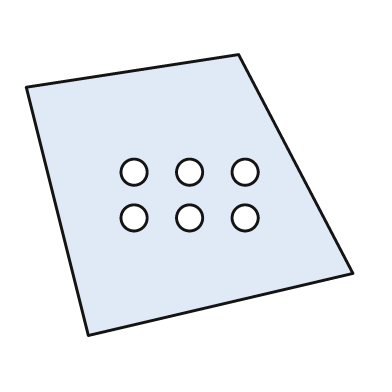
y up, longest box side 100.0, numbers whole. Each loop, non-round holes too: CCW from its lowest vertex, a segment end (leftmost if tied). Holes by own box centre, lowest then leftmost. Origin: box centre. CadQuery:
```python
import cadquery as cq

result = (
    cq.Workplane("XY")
    .moveTo(-31.0, -43.0)
    .lineTo(50.0, -24.0)
    .lineTo(15.0, 43.0)
    .lineTo(-50.0, 33.0)
    .close()
    .moveTo(-17.0, -7.0)
    .circle(4.0)
    .moveTo(0.0, -7.0)
    .circle(4.0)
    .moveTo(17.0, -7.0)
    .circle(4.0)
    .moveTo(-17.0, 7.0)
    .circle(4.0)
    .moveTo(0.0, 7.0)
    .circle(4.0)
    .moveTo(17.0, 7.0)
    .circle(4.0)
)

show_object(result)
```